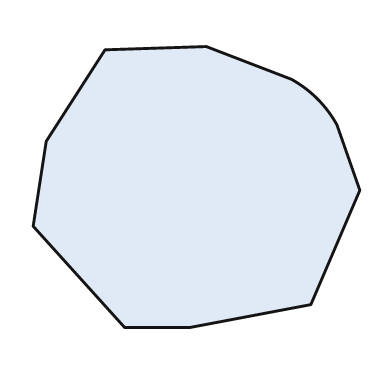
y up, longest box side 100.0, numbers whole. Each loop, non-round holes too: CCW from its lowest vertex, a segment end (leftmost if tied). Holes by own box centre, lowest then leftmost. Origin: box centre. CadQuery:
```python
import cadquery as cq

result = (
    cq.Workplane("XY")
    .moveTo(-22.0, -43.0)
    .lineTo(-2.0, -43.0)
    .lineTo(35.0, -36.0)
    .lineTo(50.0, -1.0)
    .lineTo(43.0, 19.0)
    .threePointArc((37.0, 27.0), (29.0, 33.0))
    .lineTo(3.0, 43.0)
    .lineTo(-28.0, 42.0)
    .lineTo(-46.0, 14.0)
    .lineTo(-50.0, -12.0)
    .close()
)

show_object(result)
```